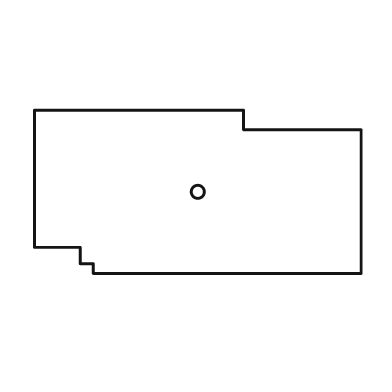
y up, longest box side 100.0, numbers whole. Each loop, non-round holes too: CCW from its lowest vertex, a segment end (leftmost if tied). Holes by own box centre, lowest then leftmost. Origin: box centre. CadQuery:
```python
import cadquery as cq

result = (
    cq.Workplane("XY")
    .moveTo(-32.0, -25.0)
    .lineTo(50.0, -25.0)
    .lineTo(50.0, 19.0)
    .lineTo(14.0, 19.0)
    .lineTo(14.0, 25.0)
    .lineTo(-50.0, 25.0)
    .lineTo(-50.0, -17.0)
    .lineTo(-36.0, -17.0)
    .lineTo(-36.0, -22.0)
    .lineTo(-32.0, -22.0)
    .close()
    .moveTo(0.0, 0.0)
    .circle(2.0)
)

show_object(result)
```